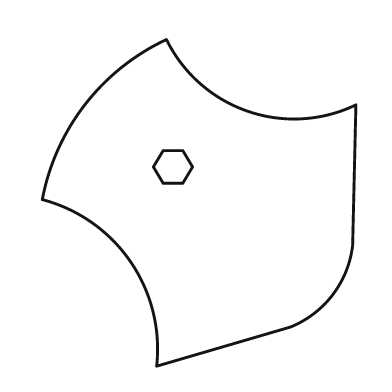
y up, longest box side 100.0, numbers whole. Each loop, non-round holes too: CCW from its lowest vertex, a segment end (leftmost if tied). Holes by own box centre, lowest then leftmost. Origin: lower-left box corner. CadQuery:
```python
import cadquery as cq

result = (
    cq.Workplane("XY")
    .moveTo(35.0, 0.0)
    .lineTo(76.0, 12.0)
    .threePointArc((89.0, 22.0), (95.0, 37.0))
    .lineTo(96.0, 80.0)
    .threePointArc((63.0, 78.0), (38.0, 100.0))
    .threePointArc((13.0, 80.0), (0.0, 51.0))
    .threePointArc((27.0, 32.0), (35.0, 0.0))
    .close()
    .moveTo(37.0, 56.0)
    .lineTo(43.0, 56.0)
    .lineTo(46.0, 61.0)
    .lineTo(43.0, 66.0)
    .lineTo(37.0, 66.0)
    .lineTo(34.0, 61.0)
    .close()
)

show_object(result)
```